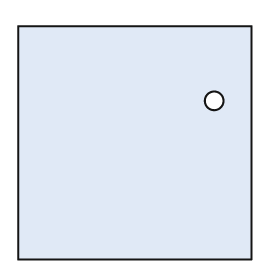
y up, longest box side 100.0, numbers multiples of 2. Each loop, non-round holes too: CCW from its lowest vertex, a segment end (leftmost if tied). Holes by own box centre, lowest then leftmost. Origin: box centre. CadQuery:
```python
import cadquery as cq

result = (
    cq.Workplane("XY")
    .moveTo(-50.0, -50.0)
    .lineTo(50.0, -50.0)
    .lineTo(50.0, 50.0)
    .lineTo(-50.0, 50.0)
    .close()
    .moveTo(34.0, 18.0)
    .circle(4.0)
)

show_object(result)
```